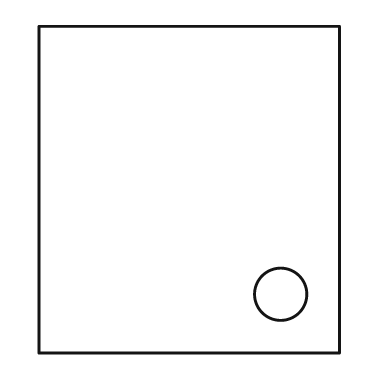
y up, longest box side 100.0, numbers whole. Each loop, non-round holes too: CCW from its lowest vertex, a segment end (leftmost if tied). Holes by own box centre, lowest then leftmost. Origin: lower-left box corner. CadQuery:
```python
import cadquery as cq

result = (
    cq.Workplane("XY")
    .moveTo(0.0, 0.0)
    .lineTo(92.0, 0.0)
    .lineTo(92.0, 100.0)
    .lineTo(0.0, 100.0)
    .close()
    .moveTo(74.0, 18.0)
    .circle(8.0)
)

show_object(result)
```